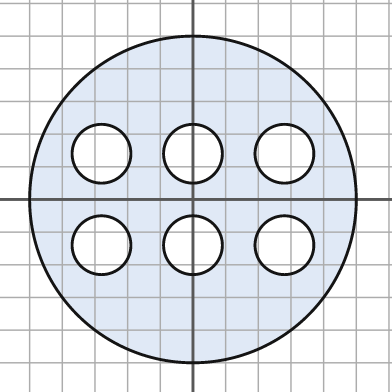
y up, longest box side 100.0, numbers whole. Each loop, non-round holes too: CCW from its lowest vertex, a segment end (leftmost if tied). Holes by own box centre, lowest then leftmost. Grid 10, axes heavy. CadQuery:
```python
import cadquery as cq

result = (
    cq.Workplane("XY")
    .moveTo(0.0, 0.0)
    .circle(50.0)
    .moveTo(-28.0, -14.0)
    .circle(9.0)
    .moveTo(0.0, -14.0)
    .circle(9.0)
    .moveTo(28.0, -14.0)
    .circle(9.0)
    .moveTo(-28.0, 14.0)
    .circle(9.0)
    .moveTo(0.0, 14.0)
    .circle(9.0)
    .moveTo(28.0, 14.0)
    .circle(9.0)
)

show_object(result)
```